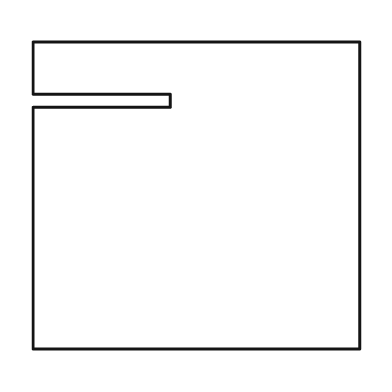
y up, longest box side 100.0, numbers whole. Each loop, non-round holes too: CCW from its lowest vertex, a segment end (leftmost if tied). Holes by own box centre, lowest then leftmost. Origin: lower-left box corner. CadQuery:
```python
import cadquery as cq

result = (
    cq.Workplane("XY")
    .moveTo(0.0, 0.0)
    .lineTo(100.0, 0.0)
    .lineTo(100.0, 94.0)
    .lineTo(0.0, 94.0)
    .lineTo(0.0, 78.0)
    .lineTo(42.0, 78.0)
    .lineTo(42.0, 74.0)
    .lineTo(0.0, 74.0)
    .close()
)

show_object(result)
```